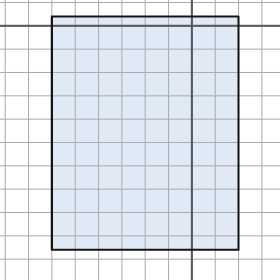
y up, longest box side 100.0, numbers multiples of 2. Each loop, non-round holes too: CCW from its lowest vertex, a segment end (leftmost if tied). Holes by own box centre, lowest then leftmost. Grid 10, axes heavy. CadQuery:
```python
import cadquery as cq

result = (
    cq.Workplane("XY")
    .moveTo(-60.0, -96.0)
    .lineTo(20.0, -96.0)
    .lineTo(20.0, 4.0)
    .lineTo(-60.0, 4.0)
    .close()
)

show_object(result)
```